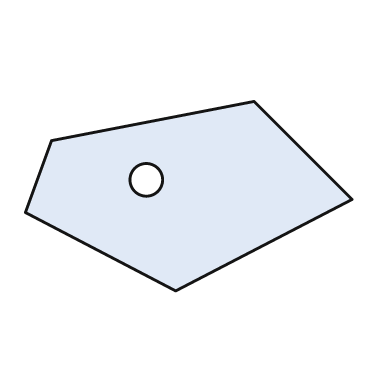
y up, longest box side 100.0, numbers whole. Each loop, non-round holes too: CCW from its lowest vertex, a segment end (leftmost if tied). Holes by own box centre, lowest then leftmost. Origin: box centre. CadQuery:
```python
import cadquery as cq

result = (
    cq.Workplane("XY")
    .moveTo(-4.0, -29.0)
    .lineTo(50.0, -1.0)
    .lineTo(20.0, 29.0)
    .lineTo(-42.0, 17.0)
    .lineTo(-50.0, -5.0)
    .close()
    .moveTo(-13.0, 5.0)
    .circle(5.0)
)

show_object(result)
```